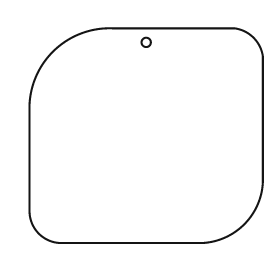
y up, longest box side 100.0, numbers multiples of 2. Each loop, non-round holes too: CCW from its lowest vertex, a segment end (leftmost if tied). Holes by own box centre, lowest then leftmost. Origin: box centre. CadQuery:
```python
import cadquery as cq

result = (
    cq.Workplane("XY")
    .moveTo(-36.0, -46.0)
    .lineTo(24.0, -46.0)
    .threePointArc((42.0, -38.0), (50.0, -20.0))
    .lineTo(50.0, 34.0)
    .threePointArc((46.0, 42.0), (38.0, 46.0))
    .lineTo(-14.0, 46.0)
    .threePointArc((-40.0, 36.0), (-50.0, 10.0))
    .lineTo(-50.0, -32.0)
    .threePointArc((-46.0, -42.0), (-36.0, -46.0))
    .close()
    .moveTo(0.0, 40.0)
    .circle(2.0)
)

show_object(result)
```